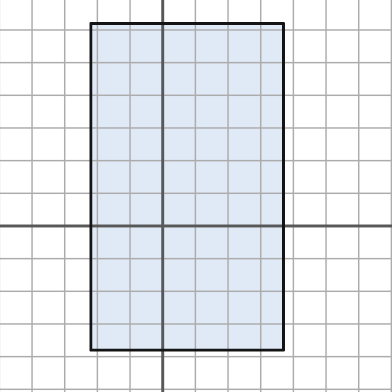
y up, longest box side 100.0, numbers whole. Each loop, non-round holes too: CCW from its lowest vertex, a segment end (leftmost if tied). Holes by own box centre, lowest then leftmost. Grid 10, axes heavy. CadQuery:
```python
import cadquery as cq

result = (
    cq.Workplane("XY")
    .moveTo(-22.0, -38.0)
    .lineTo(37.0, -38.0)
    .lineTo(37.0, 62.0)
    .lineTo(-22.0, 62.0)
    .close()
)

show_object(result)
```